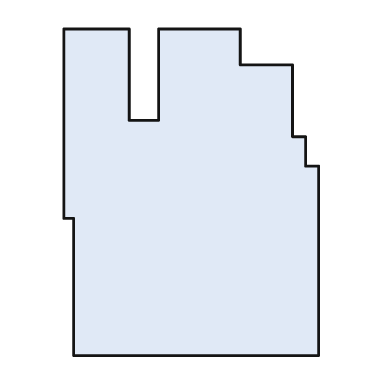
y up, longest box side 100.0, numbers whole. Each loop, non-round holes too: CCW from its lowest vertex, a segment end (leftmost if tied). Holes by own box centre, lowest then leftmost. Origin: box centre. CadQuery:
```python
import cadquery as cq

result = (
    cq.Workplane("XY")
    .moveTo(-36.0, -50.0)
    .lineTo(39.0, -50.0)
    .lineTo(39.0, 8.0)
    .lineTo(35.0, 8.0)
    .lineTo(35.0, 17.0)
    .lineTo(31.0, 17.0)
    .lineTo(31.0, 39.0)
    .lineTo(15.0, 39.0)
    .lineTo(15.0, 50.0)
    .lineTo(-10.0, 50.0)
    .lineTo(-10.0, 22.0)
    .lineTo(-19.0, 22.0)
    .lineTo(-19.0, 50.0)
    .lineTo(-39.0, 50.0)
    .lineTo(-39.0, -8.0)
    .lineTo(-36.0, -8.0)
    .close()
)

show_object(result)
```